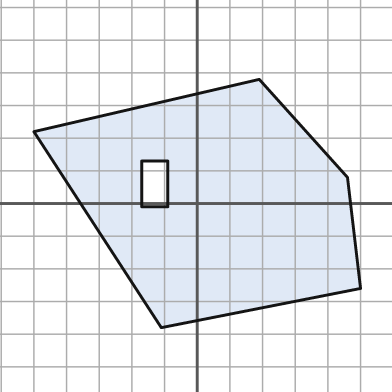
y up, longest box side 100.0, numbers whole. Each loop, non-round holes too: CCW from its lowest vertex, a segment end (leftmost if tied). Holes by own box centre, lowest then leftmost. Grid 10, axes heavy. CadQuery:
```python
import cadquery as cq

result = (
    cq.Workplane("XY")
    .moveTo(-11.0, -38.0)
    .lineTo(50.0, -26.0)
    .lineTo(46.0, 8.0)
    .lineTo(19.0, 38.0)
    .lineTo(-50.0, 22.0)
    .close()
    .moveTo(-17.0, -1.0)
    .lineTo(-9.0, -1.0)
    .lineTo(-9.0, 13.0)
    .lineTo(-17.0, 13.0)
    .close()
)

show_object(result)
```